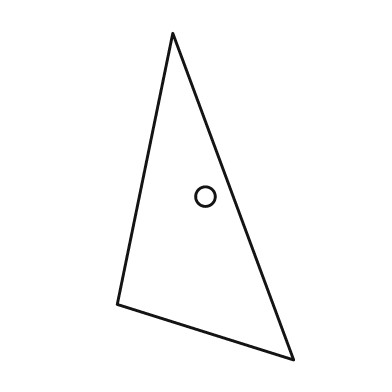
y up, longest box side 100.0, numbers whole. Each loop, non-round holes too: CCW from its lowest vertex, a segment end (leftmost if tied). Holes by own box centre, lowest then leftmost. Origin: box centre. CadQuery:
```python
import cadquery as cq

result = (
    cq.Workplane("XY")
    .moveTo(27.0, -50.0)
    .lineTo(-10.0, 50.0)
    .lineTo(-27.0, -33.0)
    .close()
    .moveTo(0.0, 0.0)
    .circle(3.0)
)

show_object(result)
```